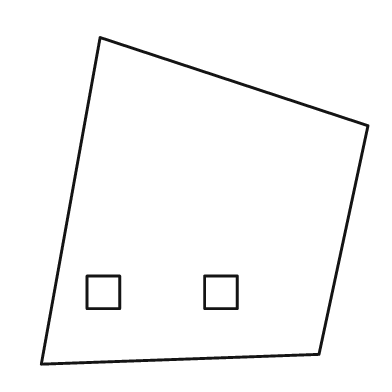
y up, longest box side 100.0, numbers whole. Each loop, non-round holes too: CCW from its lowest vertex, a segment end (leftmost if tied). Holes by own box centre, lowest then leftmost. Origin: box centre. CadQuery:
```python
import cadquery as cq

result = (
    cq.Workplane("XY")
    .moveTo(-50.0, -50.0)
    .lineTo(35.0, -47.0)
    .lineTo(50.0, 23.0)
    .lineTo(-32.0, 50.0)
    .close()
    .moveTo(-36.0, -33.0)
    .lineTo(-26.0, -33.0)
    .lineTo(-26.0, -23.0)
    .lineTo(-36.0, -23.0)
    .close()
    .moveTo(0.0, -33.0)
    .lineTo(10.0, -33.0)
    .lineTo(10.0, -23.0)
    .lineTo(0.0, -23.0)
    .close()
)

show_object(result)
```